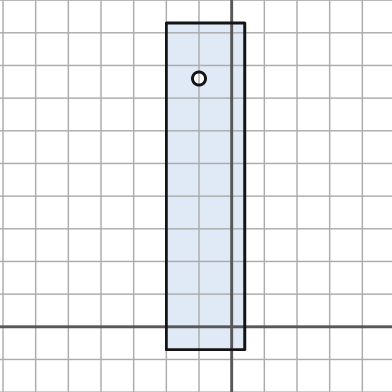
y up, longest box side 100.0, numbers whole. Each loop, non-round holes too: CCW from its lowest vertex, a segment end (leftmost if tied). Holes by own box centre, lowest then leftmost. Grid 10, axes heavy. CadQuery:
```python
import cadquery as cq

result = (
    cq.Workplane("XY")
    .moveTo(-20.0, -7.0)
    .lineTo(4.0, -7.0)
    .lineTo(4.0, 93.0)
    .lineTo(-20.0, 93.0)
    .close()
    .moveTo(-10.0, 76.0)
    .circle(2.0)
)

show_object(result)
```